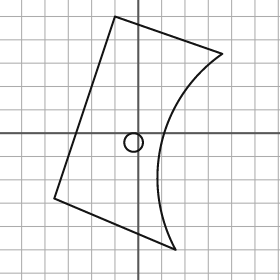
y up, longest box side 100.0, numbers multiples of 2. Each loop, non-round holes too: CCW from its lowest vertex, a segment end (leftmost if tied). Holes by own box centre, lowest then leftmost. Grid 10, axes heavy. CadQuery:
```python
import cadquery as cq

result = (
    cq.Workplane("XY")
    .moveTo(16.0, -50.0)
    .threePointArc((10.0, -4.0), (36.0, 34.0))
    .lineTo(-10.0, 50.0)
    .lineTo(-36.0, -28.0)
    .close()
    .moveTo(-2.0, -4.0)
    .circle(4.0)
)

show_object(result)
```